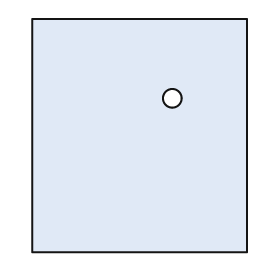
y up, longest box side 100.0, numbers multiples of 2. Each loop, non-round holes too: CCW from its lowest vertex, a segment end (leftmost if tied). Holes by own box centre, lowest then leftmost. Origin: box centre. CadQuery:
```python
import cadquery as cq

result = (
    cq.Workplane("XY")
    .moveTo(-46.0, -50.0)
    .lineTo(46.0, -50.0)
    .lineTo(46.0, 50.0)
    .lineTo(-46.0, 50.0)
    .close()
    .moveTo(14.0, 16.0)
    .circle(4.0)
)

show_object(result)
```